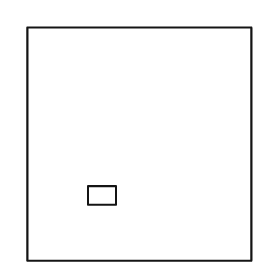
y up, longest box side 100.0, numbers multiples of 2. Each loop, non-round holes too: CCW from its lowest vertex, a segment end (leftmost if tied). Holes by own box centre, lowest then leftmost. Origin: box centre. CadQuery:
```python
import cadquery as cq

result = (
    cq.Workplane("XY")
    .moveTo(-48.0, -50.0)
    .lineTo(48.0, -50.0)
    .lineTo(48.0, 50.0)
    .lineTo(-48.0, 50.0)
    .close()
    .moveTo(-22.0, -26.0)
    .lineTo(-10.0, -26.0)
    .lineTo(-10.0, -18.0)
    .lineTo(-22.0, -18.0)
    .close()
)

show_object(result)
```